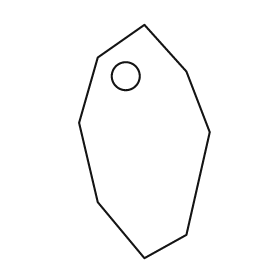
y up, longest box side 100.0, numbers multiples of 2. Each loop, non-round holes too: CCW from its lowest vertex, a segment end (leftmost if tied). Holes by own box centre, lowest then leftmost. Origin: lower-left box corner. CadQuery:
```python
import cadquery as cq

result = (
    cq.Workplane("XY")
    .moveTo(28.0, 0.0)
    .lineTo(46.0, 10.0)
    .lineTo(56.0, 54.0)
    .lineTo(46.0, 80.0)
    .lineTo(28.0, 100.0)
    .lineTo(8.0, 86.0)
    .lineTo(0.0, 58.0)
    .lineTo(8.0, 24.0)
    .close()
    .moveTo(20.0, 78.0)
    .circle(6.0)
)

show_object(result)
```